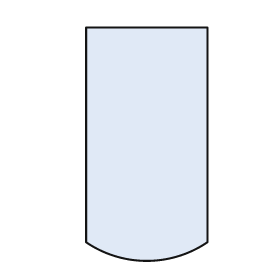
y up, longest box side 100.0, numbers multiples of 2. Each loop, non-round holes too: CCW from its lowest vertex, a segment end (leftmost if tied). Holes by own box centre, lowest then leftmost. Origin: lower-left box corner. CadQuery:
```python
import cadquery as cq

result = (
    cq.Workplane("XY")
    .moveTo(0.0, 8.0)
    .threePointArc((26.0, 0.0), (52.0, 8.0))
    .lineTo(52.0, 100.0)
    .lineTo(0.0, 100.0)
    .close()
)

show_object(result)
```